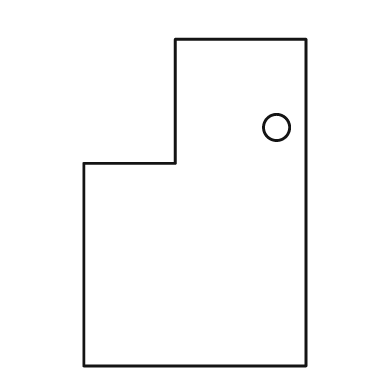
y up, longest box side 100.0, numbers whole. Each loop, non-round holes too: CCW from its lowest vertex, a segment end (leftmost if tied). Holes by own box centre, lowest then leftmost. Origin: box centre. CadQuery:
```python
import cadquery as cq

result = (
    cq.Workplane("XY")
    .moveTo(-34.0, -50.0)
    .lineTo(34.0, -50.0)
    .lineTo(34.0, 50.0)
    .lineTo(-6.0, 50.0)
    .lineTo(-6.0, 12.0)
    .lineTo(-34.0, 12.0)
    .close()
    .moveTo(25.0, 23.0)
    .circle(4.0)
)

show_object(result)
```